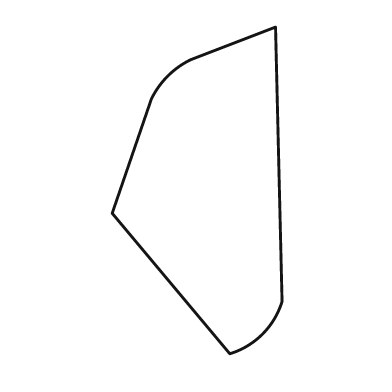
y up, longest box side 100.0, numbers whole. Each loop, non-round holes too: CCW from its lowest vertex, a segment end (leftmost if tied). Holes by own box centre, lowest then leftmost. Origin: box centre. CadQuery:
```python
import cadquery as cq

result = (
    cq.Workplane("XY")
    .moveTo(10.0, -50.0)
    .threePointArc((20.0, -44.0), (26.0, -34.0))
    .lineTo(24.0, 50.0)
    .lineTo(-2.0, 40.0)
    .threePointArc((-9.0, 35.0), (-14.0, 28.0))
    .lineTo(-26.0, -7.0)
    .close()
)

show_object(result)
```